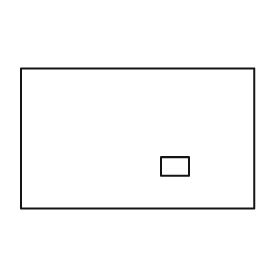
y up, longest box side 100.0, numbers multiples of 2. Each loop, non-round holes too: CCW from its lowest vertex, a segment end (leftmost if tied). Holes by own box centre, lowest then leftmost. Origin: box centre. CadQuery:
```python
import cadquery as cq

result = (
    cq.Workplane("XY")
    .moveTo(-50.0, -30.0)
    .lineTo(50.0, -30.0)
    .lineTo(50.0, 30.0)
    .lineTo(-50.0, 30.0)
    .close()
    .moveTo(10.0, -16.0)
    .lineTo(22.0, -16.0)
    .lineTo(22.0, -8.0)
    .lineTo(10.0, -8.0)
    .close()
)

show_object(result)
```